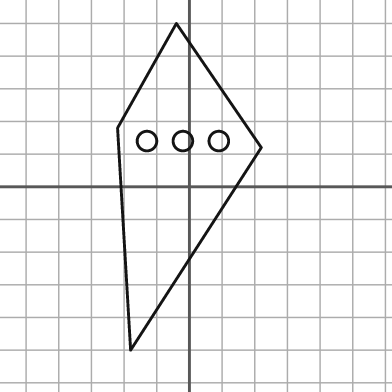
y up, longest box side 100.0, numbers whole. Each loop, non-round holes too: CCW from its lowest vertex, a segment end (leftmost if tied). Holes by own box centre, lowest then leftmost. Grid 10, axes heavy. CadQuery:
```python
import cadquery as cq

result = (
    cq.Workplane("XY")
    .moveTo(-18.0, -50.0)
    .lineTo(22.0, 12.0)
    .lineTo(-4.0, 50.0)
    .lineTo(-22.0, 18.0)
    .close()
    .moveTo(-13.0, 14.0)
    .circle(3.0)
    .moveTo(-2.0, 14.0)
    .circle(3.0)
    .moveTo(9.0, 14.0)
    .circle(3.0)
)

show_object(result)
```